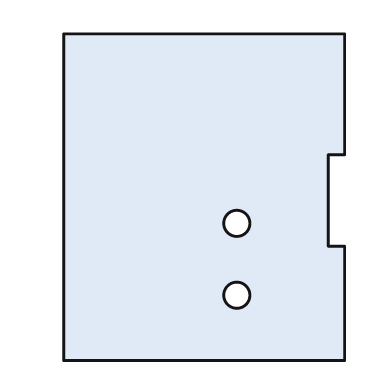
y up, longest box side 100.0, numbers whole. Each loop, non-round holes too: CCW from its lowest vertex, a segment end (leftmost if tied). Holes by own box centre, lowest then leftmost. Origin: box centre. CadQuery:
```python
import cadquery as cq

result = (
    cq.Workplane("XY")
    .moveTo(-43.0, -50.0)
    .lineTo(43.0, -50.0)
    .lineTo(43.0, -15.0)
    .lineTo(38.0, -15.0)
    .lineTo(38.0, 13.0)
    .lineTo(43.0, 13.0)
    .lineTo(43.0, 50.0)
    .lineTo(-43.0, 50.0)
    .close()
    .moveTo(10.0, -30.0)
    .circle(4.0)
    .moveTo(10.0, -8.0)
    .circle(4.0)
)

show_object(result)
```